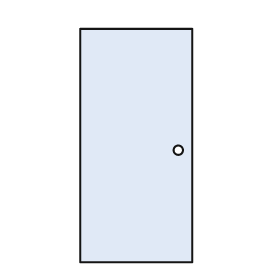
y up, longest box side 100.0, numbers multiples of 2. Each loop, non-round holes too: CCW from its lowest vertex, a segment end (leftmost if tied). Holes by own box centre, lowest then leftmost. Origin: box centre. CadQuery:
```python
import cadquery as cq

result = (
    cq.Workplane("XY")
    .moveTo(-24.0, -50.0)
    .lineTo(24.0, -50.0)
    .lineTo(24.0, 50.0)
    .lineTo(-24.0, 50.0)
    .close()
    .moveTo(18.0, -2.0)
    .circle(2.0)
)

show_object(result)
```